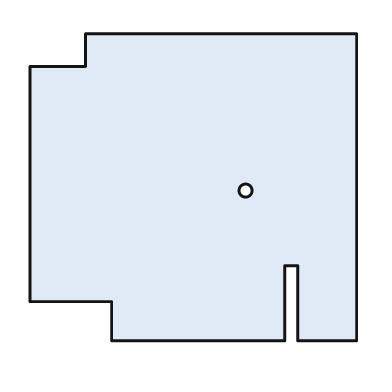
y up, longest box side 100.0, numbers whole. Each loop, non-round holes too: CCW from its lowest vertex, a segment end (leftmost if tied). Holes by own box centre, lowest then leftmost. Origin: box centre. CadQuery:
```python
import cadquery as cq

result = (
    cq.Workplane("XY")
    .moveTo(-25.0, -47.0)
    .lineTo(28.0, -47.0)
    .lineTo(28.0, -24.0)
    .lineTo(32.0, -24.0)
    .lineTo(32.0, -47.0)
    .lineTo(50.0, -47.0)
    .lineTo(50.0, 47.0)
    .lineTo(-33.0, 47.0)
    .lineTo(-33.0, 37.0)
    .lineTo(-50.0, 37.0)
    .lineTo(-50.0, -35.0)
    .lineTo(-25.0, -35.0)
    .close()
    .moveTo(16.0, -1.0)
    .circle(2.0)
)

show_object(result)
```